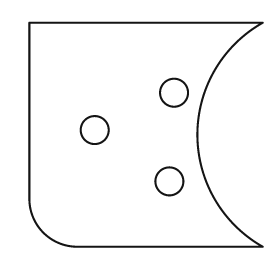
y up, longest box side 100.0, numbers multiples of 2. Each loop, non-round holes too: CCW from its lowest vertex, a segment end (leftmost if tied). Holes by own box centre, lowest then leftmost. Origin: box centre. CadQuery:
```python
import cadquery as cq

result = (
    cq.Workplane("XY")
    .moveTo(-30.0, -48.0)
    .lineTo(50.0, -48.0)
    .threePointArc((22.0, 0.0), (50.0, 48.0))
    .lineTo(-50.0, 48.0)
    .lineTo(-50.0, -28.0)
    .threePointArc((-44.0, -42.0), (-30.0, -48.0))
    .close()
    .moveTo(10.0, -20.0)
    .circle(6.0)
    .moveTo(-22.0, 2.0)
    .circle(6.0)
    .moveTo(12.0, 18.0)
    .circle(6.0)
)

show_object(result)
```